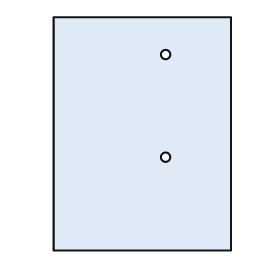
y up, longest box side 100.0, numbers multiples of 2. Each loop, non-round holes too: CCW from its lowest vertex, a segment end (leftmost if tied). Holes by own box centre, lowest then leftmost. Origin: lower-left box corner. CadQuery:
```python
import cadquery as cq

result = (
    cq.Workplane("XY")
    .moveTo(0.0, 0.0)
    .lineTo(76.0, 0.0)
    .lineTo(76.0, 100.0)
    .lineTo(0.0, 100.0)
    .close()
    .moveTo(48.0, 40.0)
    .circle(2.0)
    .moveTo(48.0, 84.0)
    .circle(2.0)
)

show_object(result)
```